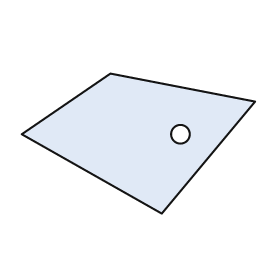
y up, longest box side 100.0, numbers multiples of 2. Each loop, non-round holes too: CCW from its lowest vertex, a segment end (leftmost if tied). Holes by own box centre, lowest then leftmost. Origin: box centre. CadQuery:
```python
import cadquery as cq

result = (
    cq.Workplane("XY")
    .moveTo(10.0, -30.0)
    .lineTo(50.0, 18.0)
    .lineTo(-12.0, 30.0)
    .lineTo(-50.0, 4.0)
    .close()
    .moveTo(18.0, 4.0)
    .circle(4.0)
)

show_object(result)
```